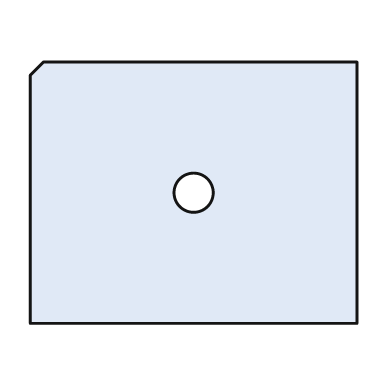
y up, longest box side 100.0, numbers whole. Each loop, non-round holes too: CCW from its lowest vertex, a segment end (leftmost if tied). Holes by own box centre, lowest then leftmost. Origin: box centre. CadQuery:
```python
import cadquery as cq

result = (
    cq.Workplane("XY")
    .moveTo(-50.0, -40.0)
    .lineTo(50.0, -40.0)
    .lineTo(50.0, 40.0)
    .lineTo(-46.0, 40.0)
    .lineTo(-50.0, 36.0)
    .close()
    .moveTo(0.0, 0.0)
    .circle(6.0)
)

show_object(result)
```